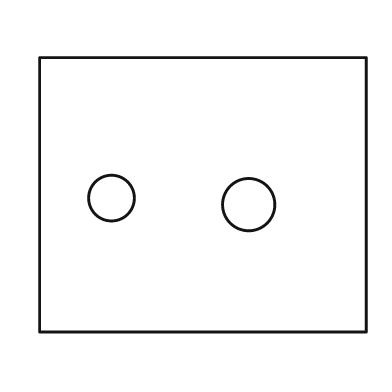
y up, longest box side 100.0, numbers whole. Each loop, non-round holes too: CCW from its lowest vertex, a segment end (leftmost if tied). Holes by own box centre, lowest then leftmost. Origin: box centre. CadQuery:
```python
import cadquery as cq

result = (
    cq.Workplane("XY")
    .moveTo(-50.0, -42.0)
    .lineTo(50.0, -42.0)
    .lineTo(50.0, 42.0)
    .lineTo(-50.0, 42.0)
    .close()
    .moveTo(14.0, -3.0)
    .circle(8.0)
    .moveTo(-28.0, -1.0)
    .circle(7.0)
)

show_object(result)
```